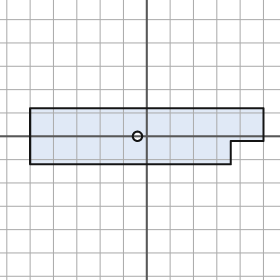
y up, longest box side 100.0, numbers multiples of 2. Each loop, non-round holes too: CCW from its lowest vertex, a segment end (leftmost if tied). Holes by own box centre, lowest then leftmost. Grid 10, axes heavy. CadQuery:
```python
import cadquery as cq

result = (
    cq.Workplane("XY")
    .moveTo(-50.0, -12.0)
    .lineTo(36.0, -12.0)
    .lineTo(36.0, -2.0)
    .lineTo(50.0, -2.0)
    .lineTo(50.0, 12.0)
    .lineTo(-50.0, 12.0)
    .close()
    .moveTo(-4.0, 0.0)
    .circle(2.0)
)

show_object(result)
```